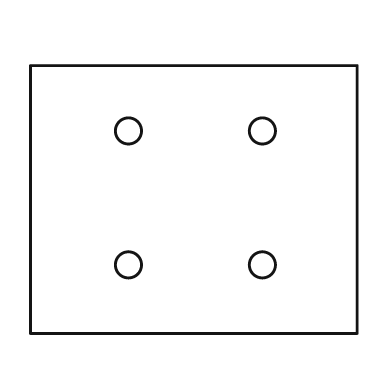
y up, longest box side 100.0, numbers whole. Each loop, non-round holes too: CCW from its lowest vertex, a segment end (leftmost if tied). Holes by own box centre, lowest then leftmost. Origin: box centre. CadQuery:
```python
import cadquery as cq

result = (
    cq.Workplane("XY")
    .moveTo(-50.0, -41.0)
    .lineTo(50.0, -41.0)
    .lineTo(50.0, 41.0)
    .lineTo(-50.0, 41.0)
    .close()
    .moveTo(-20.0, -20.0)
    .circle(4.0)
    .moveTo(21.0, -20.0)
    .circle(4.0)
    .moveTo(-20.0, 21.0)
    .circle(4.0)
    .moveTo(21.0, 21.0)
    .circle(4.0)
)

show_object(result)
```